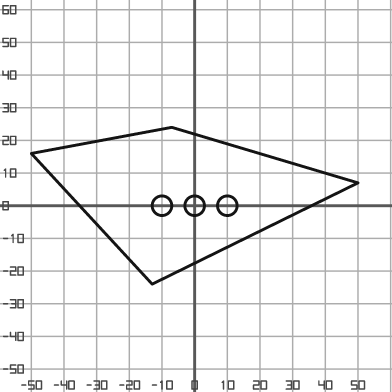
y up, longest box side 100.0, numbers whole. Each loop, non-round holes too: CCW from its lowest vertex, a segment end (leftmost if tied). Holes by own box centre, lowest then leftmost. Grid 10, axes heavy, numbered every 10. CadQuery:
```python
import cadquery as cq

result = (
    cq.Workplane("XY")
    .moveTo(-13.0, -24.0)
    .lineTo(50.0, 7.0)
    .lineTo(-7.0, 24.0)
    .lineTo(-50.0, 16.0)
    .close()
    .moveTo(-10.0, 0.0)
    .circle(3.0)
    .moveTo(0.0, 0.0)
    .circle(3.0)
    .moveTo(10.0, 0.0)
    .circle(3.0)
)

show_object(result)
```